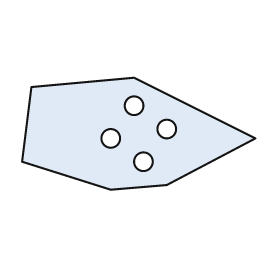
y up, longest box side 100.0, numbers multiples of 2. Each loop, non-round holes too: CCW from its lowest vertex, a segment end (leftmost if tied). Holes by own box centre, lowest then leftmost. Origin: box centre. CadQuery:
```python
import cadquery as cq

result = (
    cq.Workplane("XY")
    .moveTo(-12.0, -24.0)
    .lineTo(12.0, -22.0)
    .lineTo(50.0, -2.0)
    .lineTo(-2.0, 24.0)
    .lineTo(-46.0, 20.0)
    .lineTo(-50.0, -12.0)
    .close()
    .moveTo(2.0, -12.0)
    .circle(4.0)
    .moveTo(-12.0, -2.0)
    .circle(4.0)
    .moveTo(12.0, 2.0)
    .circle(4.0)
    .moveTo(-2.0, 12.0)
    .circle(4.0)
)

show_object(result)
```